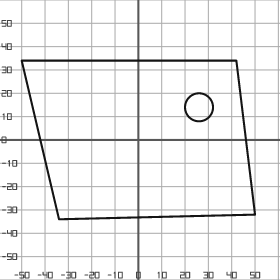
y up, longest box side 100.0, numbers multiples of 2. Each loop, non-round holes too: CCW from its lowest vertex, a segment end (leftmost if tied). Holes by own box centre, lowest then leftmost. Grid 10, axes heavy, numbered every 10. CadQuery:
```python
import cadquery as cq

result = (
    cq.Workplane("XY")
    .moveTo(-34.0, -34.0)
    .lineTo(50.0, -32.0)
    .lineTo(42.0, 34.0)
    .lineTo(-50.0, 34.0)
    .close()
    .moveTo(26.0, 14.0)
    .circle(6.0)
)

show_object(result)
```